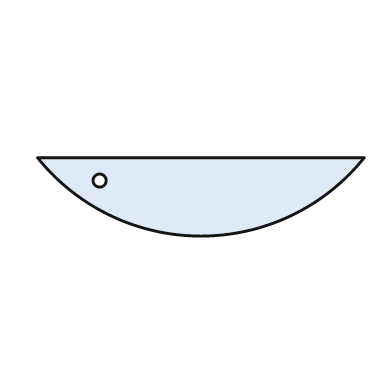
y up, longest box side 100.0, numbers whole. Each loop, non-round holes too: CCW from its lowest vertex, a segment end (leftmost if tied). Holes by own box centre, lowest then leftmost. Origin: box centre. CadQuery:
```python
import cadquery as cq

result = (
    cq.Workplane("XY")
    .moveTo(-50.0, 12.0)
    .threePointArc((0.0, -12.0), (50.0, 12.0))
    .close()
    .moveTo(-31.0, 5.0)
    .circle(2.0)
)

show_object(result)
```